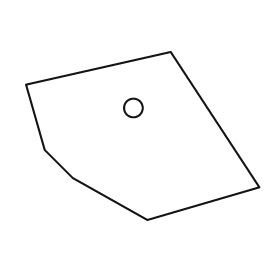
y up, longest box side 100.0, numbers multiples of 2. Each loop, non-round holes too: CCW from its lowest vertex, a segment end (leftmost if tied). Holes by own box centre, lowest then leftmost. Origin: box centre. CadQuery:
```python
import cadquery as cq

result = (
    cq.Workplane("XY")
    .moveTo(2.0, -36.0)
    .lineTo(50.0, -22.0)
    .lineTo(12.0, 36.0)
    .lineTo(-50.0, 22.0)
    .lineTo(-42.0, -6.0)
    .lineTo(-30.0, -18.0)
    .close()
    .moveTo(-4.0, 12.0)
    .circle(4.0)
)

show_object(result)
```